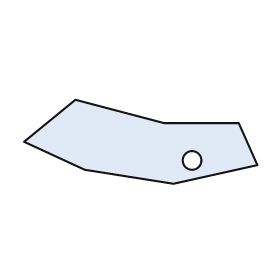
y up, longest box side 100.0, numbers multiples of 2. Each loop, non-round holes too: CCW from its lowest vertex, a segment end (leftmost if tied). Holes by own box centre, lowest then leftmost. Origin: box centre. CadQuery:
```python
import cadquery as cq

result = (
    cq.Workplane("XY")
    .moveTo(14.0, -18.0)
    .lineTo(50.0, -10.0)
    .lineTo(42.0, 8.0)
    .lineTo(10.0, 8.0)
    .lineTo(-28.0, 18.0)
    .lineTo(-50.0, 0.0)
    .lineTo(-24.0, -12.0)
    .close()
    .moveTo(22.0, -8.0)
    .circle(4.0)
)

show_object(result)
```